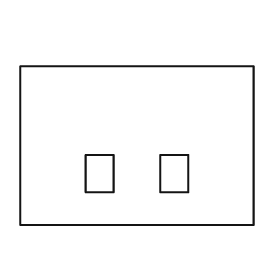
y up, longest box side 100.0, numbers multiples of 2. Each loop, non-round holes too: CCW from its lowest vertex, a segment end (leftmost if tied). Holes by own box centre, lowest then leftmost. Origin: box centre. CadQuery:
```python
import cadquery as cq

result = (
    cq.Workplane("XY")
    .moveTo(-50.0, -34.0)
    .lineTo(50.0, -34.0)
    .lineTo(50.0, 34.0)
    .lineTo(-50.0, 34.0)
    .close()
    .moveTo(-22.0, -20.0)
    .lineTo(-10.0, -20.0)
    .lineTo(-10.0, -4.0)
    .lineTo(-22.0, -4.0)
    .close()
    .moveTo(10.0, -20.0)
    .lineTo(22.0, -20.0)
    .lineTo(22.0, -4.0)
    .lineTo(10.0, -4.0)
    .close()
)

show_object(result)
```